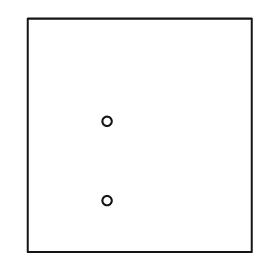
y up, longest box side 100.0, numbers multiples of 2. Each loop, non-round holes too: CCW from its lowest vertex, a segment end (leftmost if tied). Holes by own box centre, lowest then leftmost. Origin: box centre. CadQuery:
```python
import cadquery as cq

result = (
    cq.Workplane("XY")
    .moveTo(-48.0, -50.0)
    .lineTo(48.0, -50.0)
    .lineTo(48.0, 50.0)
    .lineTo(-48.0, 50.0)
    .close()
    .moveTo(-14.0, -28.0)
    .circle(2.0)
    .moveTo(-14.0, 6.0)
    .circle(2.0)
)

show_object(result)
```